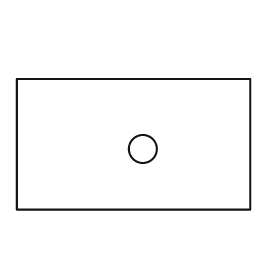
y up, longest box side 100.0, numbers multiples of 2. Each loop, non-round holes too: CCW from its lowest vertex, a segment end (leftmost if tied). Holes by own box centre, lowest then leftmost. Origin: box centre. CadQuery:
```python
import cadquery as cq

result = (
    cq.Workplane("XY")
    .moveTo(-50.0, -28.0)
    .lineTo(50.0, -28.0)
    .lineTo(50.0, 28.0)
    .lineTo(-50.0, 28.0)
    .close()
    .moveTo(4.0, -2.0)
    .circle(6.0)
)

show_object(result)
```